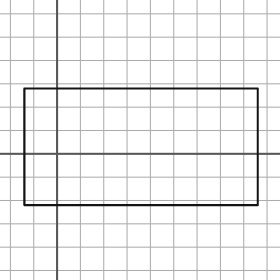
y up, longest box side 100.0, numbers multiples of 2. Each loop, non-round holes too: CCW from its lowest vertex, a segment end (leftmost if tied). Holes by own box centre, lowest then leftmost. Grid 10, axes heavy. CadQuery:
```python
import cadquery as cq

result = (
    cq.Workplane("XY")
    .moveTo(-14.0, -22.0)
    .lineTo(86.0, -22.0)
    .lineTo(86.0, 28.0)
    .lineTo(-14.0, 28.0)
    .close()
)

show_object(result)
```